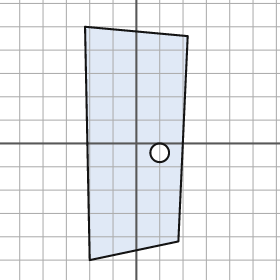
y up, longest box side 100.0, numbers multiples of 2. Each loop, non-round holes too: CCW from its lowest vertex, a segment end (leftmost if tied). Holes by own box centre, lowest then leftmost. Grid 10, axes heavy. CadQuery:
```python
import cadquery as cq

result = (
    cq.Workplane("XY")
    .moveTo(-20.0, -50.0)
    .lineTo(18.0, -42.0)
    .lineTo(22.0, 46.0)
    .lineTo(-22.0, 50.0)
    .close()
    .moveTo(10.0, -4.0)
    .circle(4.0)
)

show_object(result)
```